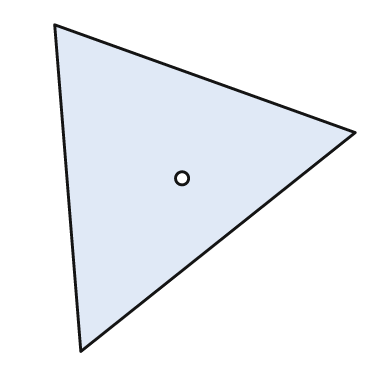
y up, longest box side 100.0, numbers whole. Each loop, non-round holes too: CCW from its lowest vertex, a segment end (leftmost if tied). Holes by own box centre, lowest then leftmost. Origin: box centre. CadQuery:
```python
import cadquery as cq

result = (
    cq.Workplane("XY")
    .moveTo(-38.0, -50.0)
    .lineTo(46.0, 17.0)
    .lineTo(-46.0, 50.0)
    .close()
    .moveTo(-7.0, 3.0)
    .circle(2.0)
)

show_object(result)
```